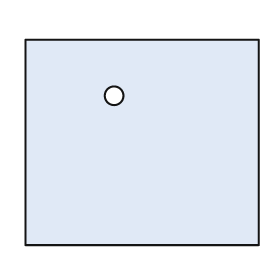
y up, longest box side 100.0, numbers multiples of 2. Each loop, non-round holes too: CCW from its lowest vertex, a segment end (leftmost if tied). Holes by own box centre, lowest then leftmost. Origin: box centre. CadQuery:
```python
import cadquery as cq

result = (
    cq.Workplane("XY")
    .moveTo(-50.0, -44.0)
    .lineTo(50.0, -44.0)
    .lineTo(50.0, 44.0)
    .lineTo(-50.0, 44.0)
    .close()
    .moveTo(-12.0, 20.0)
    .circle(4.0)
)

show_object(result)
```